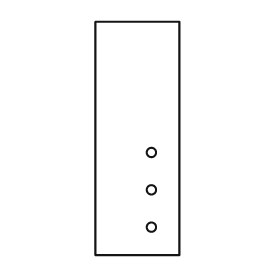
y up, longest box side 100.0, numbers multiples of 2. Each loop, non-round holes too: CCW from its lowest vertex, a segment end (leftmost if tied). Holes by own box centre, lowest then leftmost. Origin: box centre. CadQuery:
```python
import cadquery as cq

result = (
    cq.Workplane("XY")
    .moveTo(-18.0, -50.0)
    .lineTo(18.0, -50.0)
    .lineTo(18.0, 50.0)
    .lineTo(-18.0, 50.0)
    .close()
    .moveTo(6.0, -38.0)
    .circle(2.0)
    .moveTo(6.0, -22.0)
    .circle(2.0)
    .moveTo(6.0, -6.0)
    .circle(2.0)
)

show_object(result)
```